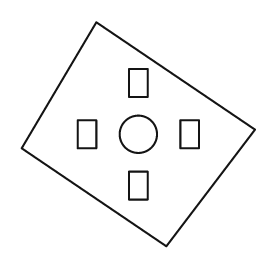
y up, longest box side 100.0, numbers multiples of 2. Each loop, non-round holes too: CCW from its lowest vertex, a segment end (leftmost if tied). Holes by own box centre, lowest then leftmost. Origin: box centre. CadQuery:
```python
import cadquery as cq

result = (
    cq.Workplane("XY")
    .moveTo(12.0, -48.0)
    .lineTo(50.0, 2.0)
    .lineTo(-18.0, 48.0)
    .lineTo(-50.0, -6.0)
    .close()
    .moveTo(-4.0, -28.0)
    .lineTo(4.0, -28.0)
    .lineTo(4.0, -16.0)
    .lineTo(-4.0, -16.0)
    .close()
    .moveTo(-26.0, -6.0)
    .lineTo(-18.0, -6.0)
    .lineTo(-18.0, 6.0)
    .lineTo(-26.0, 6.0)
    .close()
    .moveTo(0.0, 0.0)
    .circle(8.0)
    .moveTo(18.0, -6.0)
    .lineTo(26.0, -6.0)
    .lineTo(26.0, 6.0)
    .lineTo(18.0, 6.0)
    .close()
    .moveTo(-4.0, 16.0)
    .lineTo(4.0, 16.0)
    .lineTo(4.0, 28.0)
    .lineTo(-4.0, 28.0)
    .close()
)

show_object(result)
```